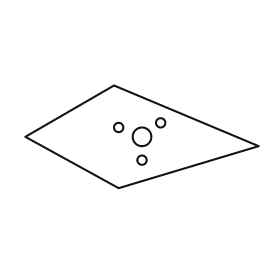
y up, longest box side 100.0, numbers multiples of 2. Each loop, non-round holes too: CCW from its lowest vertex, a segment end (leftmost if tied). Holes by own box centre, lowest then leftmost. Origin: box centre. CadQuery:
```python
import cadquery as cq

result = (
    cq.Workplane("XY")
    .moveTo(-10.0, -22.0)
    .lineTo(50.0, -4.0)
    .lineTo(-12.0, 22.0)
    .lineTo(-50.0, 0.0)
    .close()
    .moveTo(0.0, -10.0)
    .circle(2.0)
    .moveTo(0.0, 0.0)
    .circle(4.0)
    .moveTo(-10.0, 4.0)
    .circle(2.0)
    .moveTo(8.0, 6.0)
    .circle(2.0)
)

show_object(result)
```